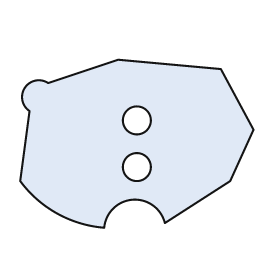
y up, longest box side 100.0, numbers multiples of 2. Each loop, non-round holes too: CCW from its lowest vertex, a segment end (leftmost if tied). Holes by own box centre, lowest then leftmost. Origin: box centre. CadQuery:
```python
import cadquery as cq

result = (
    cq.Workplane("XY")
    .moveTo(-14.0, -36.0)
    .threePointArc((-2.0, -24.0), (12.0, -34.0))
    .lineTo(40.0, -16.0)
    .lineTo(50.0, 6.0)
    .lineTo(36.0, 32.0)
    .lineTo(-8.0, 36.0)
    .lineTo(-38.0, 26.0)
    .threePointArc((-48.0, 24.0), (-46.0, 14.0))
    .lineTo(-50.0, -16.0)
    .threePointArc((-34.0, -30.0), (-14.0, -36.0))
    .close()
    .moveTo(0.0, -10.0)
    .circle(6.0)
    .moveTo(0.0, 10.0)
    .circle(6.0)
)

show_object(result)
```